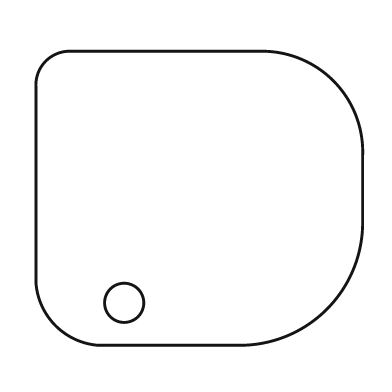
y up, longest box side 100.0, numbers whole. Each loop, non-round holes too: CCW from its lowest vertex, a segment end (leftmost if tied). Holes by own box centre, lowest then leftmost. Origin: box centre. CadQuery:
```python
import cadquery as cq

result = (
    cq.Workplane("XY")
    .moveTo(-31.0, -45.0)
    .lineTo(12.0, -45.0)
    .threePointArc((39.0, -34.0), (50.0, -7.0))
    .lineTo(50.0, 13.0)
    .threePointArc((41.0, 36.0), (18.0, 45.0))
    .lineTo(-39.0, 45.0)
    .threePointArc((-47.0, 42.0), (-50.0, 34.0))
    .lineTo(-50.0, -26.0)
    .threePointArc((-44.0, -39.0), (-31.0, -45.0))
    .close()
    .moveTo(-23.0, -32.0)
    .circle(6.0)
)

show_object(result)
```